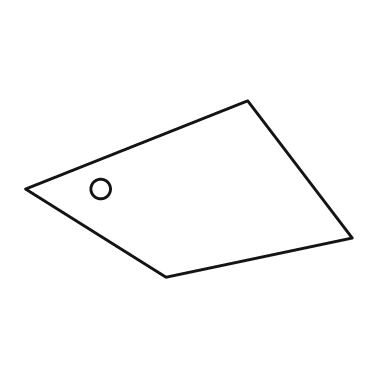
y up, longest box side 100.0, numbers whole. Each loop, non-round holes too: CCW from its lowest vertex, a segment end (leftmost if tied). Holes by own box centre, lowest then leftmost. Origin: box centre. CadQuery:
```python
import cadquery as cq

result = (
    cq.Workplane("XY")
    .moveTo(-7.0, -27.0)
    .lineTo(50.0, -15.0)
    .lineTo(18.0, 27.0)
    .lineTo(-50.0, 0.0)
    .close()
    .moveTo(-27.0, 0.0)
    .circle(3.0)
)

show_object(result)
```